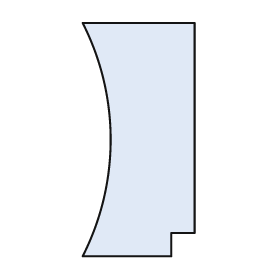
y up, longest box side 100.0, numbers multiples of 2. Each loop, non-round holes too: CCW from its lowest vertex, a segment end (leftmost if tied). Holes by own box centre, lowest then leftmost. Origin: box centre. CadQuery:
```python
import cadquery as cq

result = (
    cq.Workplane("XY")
    .moveTo(-24.0, -50.0)
    .lineTo(14.0, -50.0)
    .lineTo(14.0, -40.0)
    .lineTo(24.0, -40.0)
    .lineTo(24.0, 50.0)
    .lineTo(-24.0, 50.0)
    .threePointArc((-12.0, 0.0), (-24.0, -50.0))
    .close()
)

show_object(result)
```